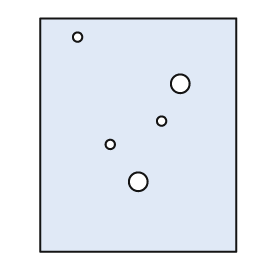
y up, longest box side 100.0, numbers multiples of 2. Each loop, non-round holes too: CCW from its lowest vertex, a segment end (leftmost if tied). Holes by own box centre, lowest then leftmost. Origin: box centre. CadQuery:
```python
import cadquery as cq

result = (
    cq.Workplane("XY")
    .moveTo(-42.0, -50.0)
    .lineTo(42.0, -50.0)
    .lineTo(42.0, 50.0)
    .lineTo(-42.0, 50.0)
    .close()
    .moveTo(0.0, -20.0)
    .circle(4.0)
    .moveTo(-12.0, -4.0)
    .circle(2.0)
    .moveTo(10.0, 6.0)
    .circle(2.0)
    .moveTo(18.0, 22.0)
    .circle(4.0)
    .moveTo(-26.0, 42.0)
    .circle(2.0)
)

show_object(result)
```